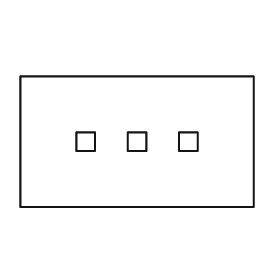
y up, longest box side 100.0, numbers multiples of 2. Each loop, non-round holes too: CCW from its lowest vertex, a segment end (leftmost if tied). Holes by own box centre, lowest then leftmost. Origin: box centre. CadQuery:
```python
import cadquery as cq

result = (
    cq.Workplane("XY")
    .moveTo(-50.0, -28.0)
    .lineTo(50.0, -28.0)
    .lineTo(50.0, 28.0)
    .lineTo(-50.0, 28.0)
    .close()
    .moveTo(-26.0, -4.0)
    .lineTo(-18.0, -4.0)
    .lineTo(-18.0, 4.0)
    .lineTo(-26.0, 4.0)
    .close()
    .moveTo(-4.0, -4.0)
    .lineTo(4.0, -4.0)
    .lineTo(4.0, 4.0)
    .lineTo(-4.0, 4.0)
    .close()
    .moveTo(18.0, -4.0)
    .lineTo(26.0, -4.0)
    .lineTo(26.0, 4.0)
    .lineTo(18.0, 4.0)
    .close()
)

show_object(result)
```